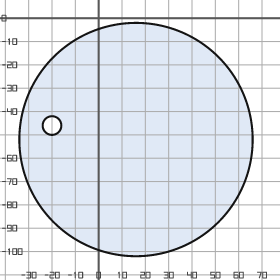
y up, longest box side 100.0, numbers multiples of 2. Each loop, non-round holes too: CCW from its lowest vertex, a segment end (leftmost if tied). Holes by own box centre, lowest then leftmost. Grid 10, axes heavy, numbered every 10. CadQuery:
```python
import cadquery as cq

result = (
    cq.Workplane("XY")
    .moveTo(16.0, -52.0)
    .circle(50.0)
    .moveTo(-20.0, -46.0)
    .circle(4.0)
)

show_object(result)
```